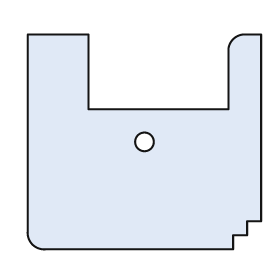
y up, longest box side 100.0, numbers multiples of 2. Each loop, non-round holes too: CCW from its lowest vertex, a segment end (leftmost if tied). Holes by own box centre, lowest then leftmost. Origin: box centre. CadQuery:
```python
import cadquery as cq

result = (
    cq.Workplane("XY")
    .moveTo(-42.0, -46.0)
    .lineTo(38.0, -46.0)
    .lineTo(38.0, -40.0)
    .lineTo(44.0, -40.0)
    .lineTo(44.0, -34.0)
    .lineTo(50.0, -34.0)
    .lineTo(50.0, 46.0)
    .lineTo(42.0, 46.0)
    .threePointArc((38.0, 44.0), (36.0, 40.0))
    .lineTo(36.0, 14.0)
    .lineTo(-24.0, 14.0)
    .lineTo(-24.0, 46.0)
    .lineTo(-50.0, 46.0)
    .lineTo(-50.0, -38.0)
    .threePointArc((-48.0, -44.0), (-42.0, -46.0))
    .close()
    .moveTo(0.0, 0.0)
    .circle(4.0)
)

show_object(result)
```